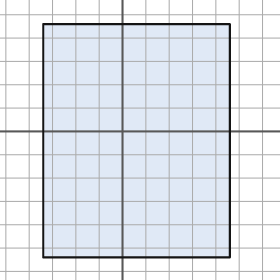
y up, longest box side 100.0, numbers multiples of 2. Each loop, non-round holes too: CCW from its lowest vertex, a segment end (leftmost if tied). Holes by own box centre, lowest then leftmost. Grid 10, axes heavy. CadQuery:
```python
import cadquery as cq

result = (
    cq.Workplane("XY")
    .moveTo(-34.0, -54.0)
    .lineTo(46.0, -54.0)
    .lineTo(46.0, 46.0)
    .lineTo(-34.0, 46.0)
    .close()
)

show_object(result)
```